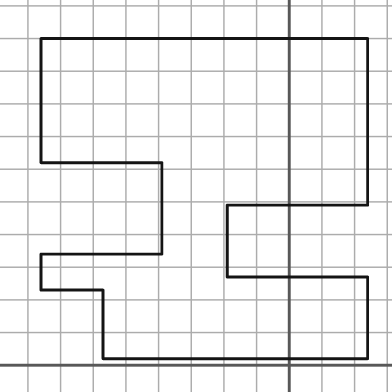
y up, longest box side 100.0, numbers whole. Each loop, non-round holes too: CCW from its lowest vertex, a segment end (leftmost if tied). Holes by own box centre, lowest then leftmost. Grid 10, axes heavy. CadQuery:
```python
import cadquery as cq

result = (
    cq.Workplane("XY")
    .moveTo(-57.0, 2.0)
    .lineTo(24.0, 2.0)
    .lineTo(24.0, 27.0)
    .lineTo(-19.0, 27.0)
    .lineTo(-19.0, 49.0)
    .lineTo(24.0, 49.0)
    .lineTo(24.0, 100.0)
    .lineTo(-76.0, 100.0)
    .lineTo(-76.0, 62.0)
    .lineTo(-39.0, 62.0)
    .lineTo(-39.0, 34.0)
    .lineTo(-76.0, 34.0)
    .lineTo(-76.0, 23.0)
    .lineTo(-57.0, 23.0)
    .close()
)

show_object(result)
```